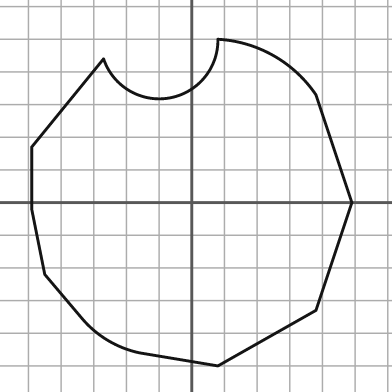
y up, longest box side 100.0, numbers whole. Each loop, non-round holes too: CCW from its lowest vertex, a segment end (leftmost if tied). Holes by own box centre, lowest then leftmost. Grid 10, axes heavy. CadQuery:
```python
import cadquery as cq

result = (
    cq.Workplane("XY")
    .moveTo(8.0, -50.0)
    .lineTo(38.0, -33.0)
    .lineTo(49.0, 0.0)
    .lineTo(38.0, 33.0)
    .threePointArc((25.0, 45.0), (8.0, 50.0))
    .threePointArc((-7.0, 32.0), (-27.0, 44.0))
    .lineTo(-49.0, 17.0)
    .lineTo(-49.0, -2.0)
    .lineTo(-45.0, -22.0)
    .lineTo(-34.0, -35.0)
    .threePointArc((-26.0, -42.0), (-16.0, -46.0))
    .close()
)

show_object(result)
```